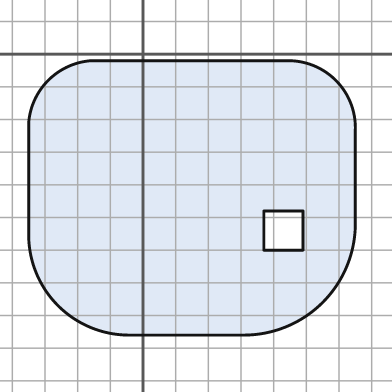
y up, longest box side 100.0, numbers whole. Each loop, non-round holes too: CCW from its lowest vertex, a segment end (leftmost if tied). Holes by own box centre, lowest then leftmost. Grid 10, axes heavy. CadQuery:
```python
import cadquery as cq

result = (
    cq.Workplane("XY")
    .moveTo(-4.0, -86.0)
    .lineTo(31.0, -86.0)
    .threePointArc((55.0, -76.0), (65.0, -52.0))
    .lineTo(65.0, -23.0)
    .threePointArc((59.0, -8.0), (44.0, -2.0))
    .lineTo(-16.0, -2.0)
    .threePointArc((-29.0, -8.0), (-35.0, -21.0))
    .lineTo(-35.0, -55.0)
    .threePointArc((-26.0, -77.0), (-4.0, -86.0))
    .close()
    .moveTo(37.0, -60.0)
    .lineTo(49.0, -60.0)
    .lineTo(49.0, -48.0)
    .lineTo(37.0, -48.0)
    .close()
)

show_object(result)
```